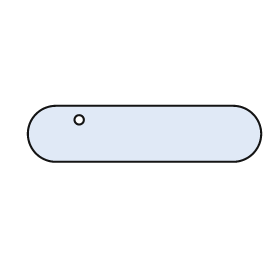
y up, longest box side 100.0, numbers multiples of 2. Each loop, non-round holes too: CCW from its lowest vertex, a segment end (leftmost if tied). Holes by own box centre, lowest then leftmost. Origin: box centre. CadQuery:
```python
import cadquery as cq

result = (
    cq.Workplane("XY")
    .moveTo(-38.0, -12.0)
    .lineTo(38.0, -12.0)
    .threePointArc((50.0, 0.0), (38.0, 12.0))
    .lineTo(-38.0, 12.0)
    .threePointArc((-50.0, 0.0), (-38.0, -12.0))
    .close()
    .moveTo(-28.0, 6.0)
    .circle(2.0)
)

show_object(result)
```